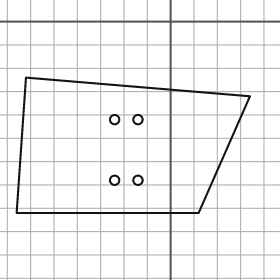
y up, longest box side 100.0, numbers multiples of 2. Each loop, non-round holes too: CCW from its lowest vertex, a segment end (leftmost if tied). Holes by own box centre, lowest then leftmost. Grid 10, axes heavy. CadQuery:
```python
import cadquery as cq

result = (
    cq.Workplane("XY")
    .moveTo(-66.0, -82.0)
    .lineTo(12.0, -82.0)
    .lineTo(34.0, -32.0)
    .lineTo(-62.0, -24.0)
    .close()
    .moveTo(-24.0, -68.0)
    .circle(2.0)
    .moveTo(-14.0, -68.0)
    .circle(2.0)
    .moveTo(-24.0, -42.0)
    .circle(2.0)
    .moveTo(-14.0, -42.0)
    .circle(2.0)
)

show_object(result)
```